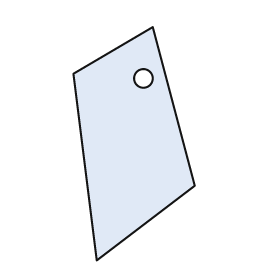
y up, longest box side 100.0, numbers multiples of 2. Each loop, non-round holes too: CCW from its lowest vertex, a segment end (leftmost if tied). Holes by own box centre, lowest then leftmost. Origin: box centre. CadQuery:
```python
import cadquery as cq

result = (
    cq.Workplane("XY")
    .moveTo(-16.0, -50.0)
    .lineTo(26.0, -18.0)
    .lineTo(8.0, 50.0)
    .lineTo(-26.0, 30.0)
    .close()
    .moveTo(4.0, 28.0)
    .circle(4.0)
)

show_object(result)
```